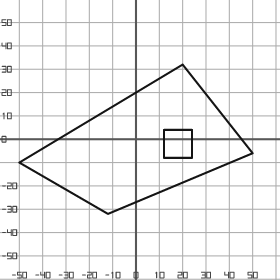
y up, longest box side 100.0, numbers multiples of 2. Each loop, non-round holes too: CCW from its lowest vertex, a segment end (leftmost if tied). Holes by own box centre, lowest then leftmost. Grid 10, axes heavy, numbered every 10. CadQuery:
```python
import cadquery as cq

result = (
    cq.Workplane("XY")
    .moveTo(-12.0, -32.0)
    .lineTo(50.0, -6.0)
    .lineTo(20.0, 32.0)
    .lineTo(-50.0, -10.0)
    .close()
    .moveTo(12.0, -8.0)
    .lineTo(24.0, -8.0)
    .lineTo(24.0, 4.0)
    .lineTo(12.0, 4.0)
    .close()
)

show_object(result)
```